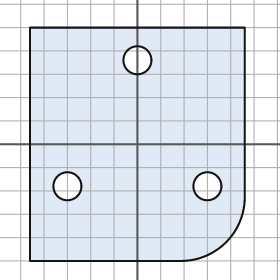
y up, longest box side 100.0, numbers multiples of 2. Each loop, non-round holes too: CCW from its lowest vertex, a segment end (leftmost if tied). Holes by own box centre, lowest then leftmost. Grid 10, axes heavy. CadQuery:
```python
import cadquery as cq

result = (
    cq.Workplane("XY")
    .moveTo(-46.0, -50.0)
    .lineTo(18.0, -50.0)
    .threePointArc((38.0, -42.0), (46.0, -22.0))
    .lineTo(46.0, 50.0)
    .lineTo(-46.0, 50.0)
    .close()
    .moveTo(-30.0, -18.0)
    .circle(6.0)
    .moveTo(30.0, -18.0)
    .circle(6.0)
    .moveTo(0.0, 36.0)
    .circle(6.0)
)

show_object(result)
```